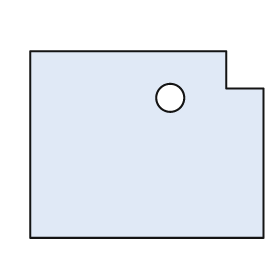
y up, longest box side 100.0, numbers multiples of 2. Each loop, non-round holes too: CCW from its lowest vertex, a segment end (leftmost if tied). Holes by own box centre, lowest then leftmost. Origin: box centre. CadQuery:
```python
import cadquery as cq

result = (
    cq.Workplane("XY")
    .moveTo(-50.0, -40.0)
    .lineTo(50.0, -40.0)
    .lineTo(50.0, 24.0)
    .lineTo(34.0, 24.0)
    .lineTo(34.0, 40.0)
    .lineTo(-50.0, 40.0)
    .close()
    .moveTo(10.0, 20.0)
    .circle(6.0)
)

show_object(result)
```